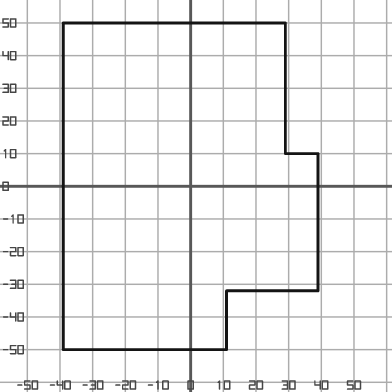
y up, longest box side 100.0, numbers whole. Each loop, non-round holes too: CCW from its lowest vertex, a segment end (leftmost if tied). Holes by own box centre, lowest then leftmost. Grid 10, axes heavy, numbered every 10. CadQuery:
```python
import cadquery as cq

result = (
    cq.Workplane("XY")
    .moveTo(-39.0, -50.0)
    .lineTo(11.0, -50.0)
    .lineTo(11.0, -32.0)
    .lineTo(39.0, -32.0)
    .lineTo(39.0, 10.0)
    .lineTo(29.0, 10.0)
    .lineTo(29.0, 50.0)
    .lineTo(-39.0, 50.0)
    .close()
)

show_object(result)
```